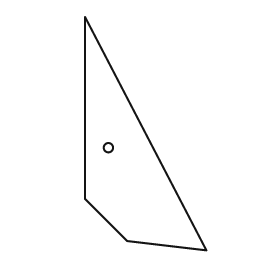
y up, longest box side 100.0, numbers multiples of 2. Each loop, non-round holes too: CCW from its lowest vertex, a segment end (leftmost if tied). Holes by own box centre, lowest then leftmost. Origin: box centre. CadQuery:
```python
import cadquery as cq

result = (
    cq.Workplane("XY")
    .moveTo(26.0, -50.0)
    .lineTo(-26.0, 50.0)
    .lineTo(-26.0, -28.0)
    .lineTo(-8.0, -46.0)
    .close()
    .moveTo(-16.0, -6.0)
    .circle(2.0)
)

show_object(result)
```